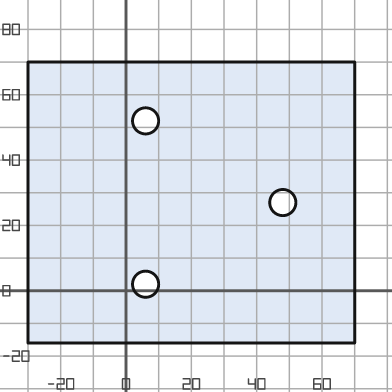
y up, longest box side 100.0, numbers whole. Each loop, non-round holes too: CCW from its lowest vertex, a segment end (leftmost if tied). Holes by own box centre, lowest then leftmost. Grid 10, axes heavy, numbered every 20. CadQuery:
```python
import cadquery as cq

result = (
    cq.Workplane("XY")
    .moveTo(-30.0, -16.0)
    .lineTo(70.0, -16.0)
    .lineTo(70.0, 70.0)
    .lineTo(-30.0, 70.0)
    .close()
    .moveTo(6.0, 2.0)
    .circle(4.0)
    .moveTo(48.0, 27.0)
    .circle(4.0)
    .moveTo(6.0, 52.0)
    .circle(4.0)
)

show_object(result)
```